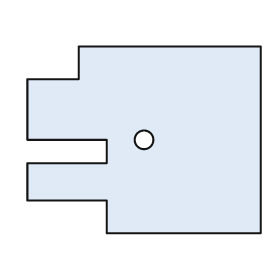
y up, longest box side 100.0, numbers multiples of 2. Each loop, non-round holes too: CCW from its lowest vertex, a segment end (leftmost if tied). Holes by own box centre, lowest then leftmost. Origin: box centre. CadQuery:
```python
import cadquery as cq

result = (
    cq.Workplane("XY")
    .moveTo(-16.0, -40.0)
    .lineTo(50.0, -40.0)
    .lineTo(50.0, 40.0)
    .lineTo(-28.0, 40.0)
    .lineTo(-28.0, 26.0)
    .lineTo(-50.0, 26.0)
    .lineTo(-50.0, 0.0)
    .lineTo(-16.0, 0.0)
    .lineTo(-16.0, -10.0)
    .lineTo(-50.0, -10.0)
    .lineTo(-50.0, -26.0)
    .lineTo(-16.0, -26.0)
    .close()
    .moveTo(0.0, 0.0)
    .circle(4.0)
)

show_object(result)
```